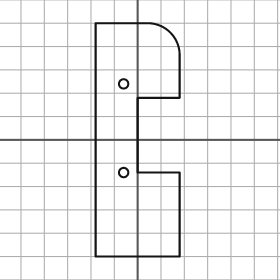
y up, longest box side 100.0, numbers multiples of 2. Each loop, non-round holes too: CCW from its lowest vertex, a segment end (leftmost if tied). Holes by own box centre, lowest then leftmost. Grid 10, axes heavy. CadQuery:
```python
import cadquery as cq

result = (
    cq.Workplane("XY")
    .moveTo(-18.0, -50.0)
    .lineTo(18.0, -50.0)
    .lineTo(18.0, -14.0)
    .lineTo(0.0, -14.0)
    .lineTo(0.0, 18.0)
    .lineTo(18.0, 18.0)
    .lineTo(18.0, 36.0)
    .threePointArc((14.0, 46.0), (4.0, 50.0))
    .lineTo(-18.0, 50.0)
    .close()
    .moveTo(-6.0, -14.0)
    .circle(2.0)
    .moveTo(-6.0, 24.0)
    .circle(2.0)
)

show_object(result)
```